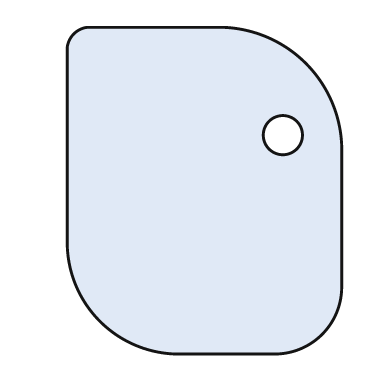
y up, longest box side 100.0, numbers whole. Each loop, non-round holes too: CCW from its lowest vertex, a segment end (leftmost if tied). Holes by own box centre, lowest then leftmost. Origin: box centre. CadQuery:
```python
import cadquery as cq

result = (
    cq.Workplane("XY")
    .moveTo(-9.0, -50.0)
    .lineTo(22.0, -50.0)
    .threePointArc((36.0, -44.0), (42.0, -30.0))
    .lineTo(42.0, 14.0)
    .threePointArc((31.0, 39.0), (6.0, 50.0))
    .lineTo(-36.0, 50.0)
    .threePointArc((-40.0, 48.0), (-42.0, 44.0))
    .lineTo(-42.0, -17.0)
    .threePointArc((-32.0, -40.0), (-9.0, -50.0))
    .close()
    .moveTo(24.0, 17.0)
    .circle(6.0)
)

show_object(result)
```